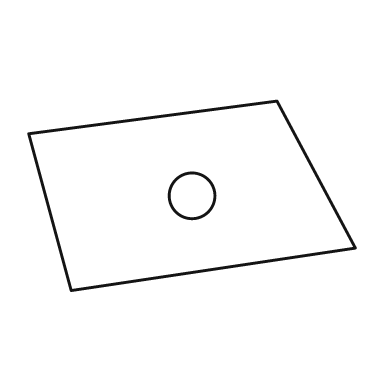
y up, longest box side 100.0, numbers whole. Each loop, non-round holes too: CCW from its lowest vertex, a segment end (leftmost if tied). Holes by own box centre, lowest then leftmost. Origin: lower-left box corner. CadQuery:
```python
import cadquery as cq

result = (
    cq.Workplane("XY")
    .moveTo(13.0, 0.0)
    .lineTo(100.0, 13.0)
    .lineTo(76.0, 58.0)
    .lineTo(0.0, 48.0)
    .close()
    .moveTo(50.0, 29.0)
    .circle(7.0)
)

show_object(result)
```